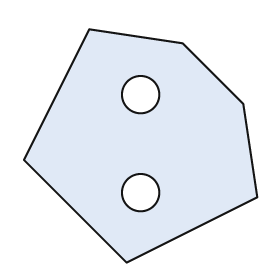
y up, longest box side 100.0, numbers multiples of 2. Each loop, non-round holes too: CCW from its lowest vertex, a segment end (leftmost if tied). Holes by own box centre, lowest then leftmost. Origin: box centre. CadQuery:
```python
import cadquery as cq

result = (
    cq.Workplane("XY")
    .moveTo(-6.0, -50.0)
    .lineTo(50.0, -22.0)
    .lineTo(44.0, 18.0)
    .lineTo(18.0, 44.0)
    .lineTo(-22.0, 50.0)
    .lineTo(-50.0, -6.0)
    .close()
    .moveTo(0.0, -20.0)
    .circle(8.0)
    .moveTo(0.0, 22.0)
    .circle(8.0)
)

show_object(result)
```